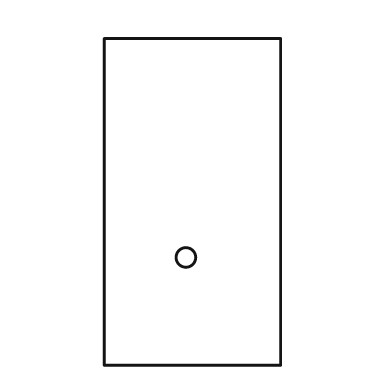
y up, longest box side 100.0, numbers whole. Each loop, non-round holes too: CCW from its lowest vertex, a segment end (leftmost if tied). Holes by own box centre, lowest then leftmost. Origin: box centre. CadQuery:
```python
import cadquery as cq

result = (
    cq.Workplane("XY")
    .moveTo(-27.0, -50.0)
    .lineTo(27.0, -50.0)
    .lineTo(27.0, 50.0)
    .lineTo(-27.0, 50.0)
    .close()
    .moveTo(-2.0, -17.0)
    .circle(3.0)
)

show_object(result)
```